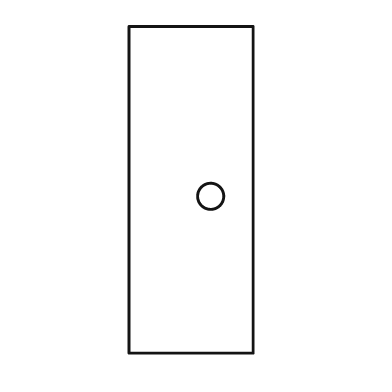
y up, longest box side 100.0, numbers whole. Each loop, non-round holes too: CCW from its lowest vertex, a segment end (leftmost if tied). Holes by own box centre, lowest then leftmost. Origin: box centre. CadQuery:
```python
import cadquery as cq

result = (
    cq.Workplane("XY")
    .moveTo(-19.0, -50.0)
    .lineTo(19.0, -50.0)
    .lineTo(19.0, 50.0)
    .lineTo(-19.0, 50.0)
    .close()
    .moveTo(6.0, -2.0)
    .circle(4.0)
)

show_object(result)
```